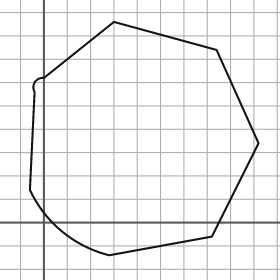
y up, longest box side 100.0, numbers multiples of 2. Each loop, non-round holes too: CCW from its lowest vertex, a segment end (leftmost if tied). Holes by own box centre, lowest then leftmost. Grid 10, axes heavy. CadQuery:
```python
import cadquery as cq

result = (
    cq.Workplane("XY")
    .moveTo(28.0, -14.0)
    .lineTo(72.0, -6.0)
    .lineTo(92.0, 34.0)
    .lineTo(74.0, 74.0)
    .lineTo(30.0, 86.0)
    .lineTo(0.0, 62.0)
    .threePointArc((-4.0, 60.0), (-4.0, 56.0))
    .lineTo(-6.0, 14.0)
    .threePointArc((8.0, -4.0), (28.0, -14.0))
    .close()
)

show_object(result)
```